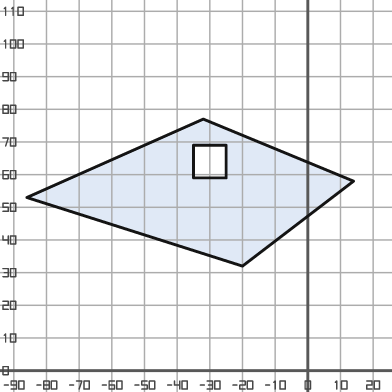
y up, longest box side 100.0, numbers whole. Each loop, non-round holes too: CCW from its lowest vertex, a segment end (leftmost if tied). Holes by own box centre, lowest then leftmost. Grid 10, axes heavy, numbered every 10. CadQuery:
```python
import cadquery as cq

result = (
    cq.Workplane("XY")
    .moveTo(-20.0, 32.0)
    .lineTo(14.0, 58.0)
    .lineTo(-32.0, 77.0)
    .lineTo(-86.0, 53.0)
    .close()
    .moveTo(-35.0, 59.0)
    .lineTo(-25.0, 59.0)
    .lineTo(-25.0, 69.0)
    .lineTo(-35.0, 69.0)
    .close()
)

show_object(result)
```